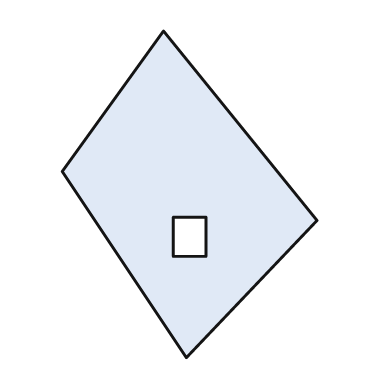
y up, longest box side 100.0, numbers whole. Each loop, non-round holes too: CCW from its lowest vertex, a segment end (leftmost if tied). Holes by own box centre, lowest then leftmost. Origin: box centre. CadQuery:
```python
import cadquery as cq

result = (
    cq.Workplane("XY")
    .moveTo(-1.0, -50.0)
    .lineTo(39.0, -8.0)
    .lineTo(-8.0, 50.0)
    .lineTo(-39.0, 7.0)
    .close()
    .moveTo(-5.0, -19.0)
    .lineTo(5.0, -19.0)
    .lineTo(5.0, -7.0)
    .lineTo(-5.0, -7.0)
    .close()
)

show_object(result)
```